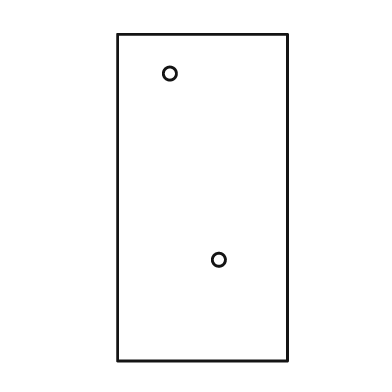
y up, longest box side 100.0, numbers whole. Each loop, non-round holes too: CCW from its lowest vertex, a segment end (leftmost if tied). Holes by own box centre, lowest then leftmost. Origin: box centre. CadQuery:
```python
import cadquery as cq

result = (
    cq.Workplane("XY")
    .moveTo(-26.0, -50.0)
    .lineTo(26.0, -50.0)
    .lineTo(26.0, 50.0)
    .lineTo(-26.0, 50.0)
    .close()
    .moveTo(5.0, -19.0)
    .circle(2.0)
    .moveTo(-10.0, 38.0)
    .circle(2.0)
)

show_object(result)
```